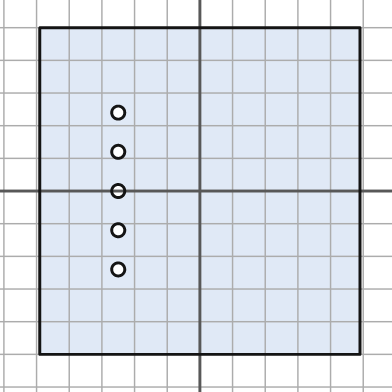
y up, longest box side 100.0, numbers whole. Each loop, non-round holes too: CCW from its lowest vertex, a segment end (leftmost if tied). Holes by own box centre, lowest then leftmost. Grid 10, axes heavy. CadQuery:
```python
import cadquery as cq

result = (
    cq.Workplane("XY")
    .moveTo(-49.0, -50.0)
    .lineTo(49.0, -50.0)
    .lineTo(49.0, 50.0)
    .lineTo(-49.0, 50.0)
    .close()
    .moveTo(-25.0, -24.0)
    .circle(2.0)
    .moveTo(-25.0, -12.0)
    .circle(2.0)
    .moveTo(-25.0, 0.0)
    .circle(2.0)
    .moveTo(-25.0, 12.0)
    .circle(2.0)
    .moveTo(-25.0, 24.0)
    .circle(2.0)
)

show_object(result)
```